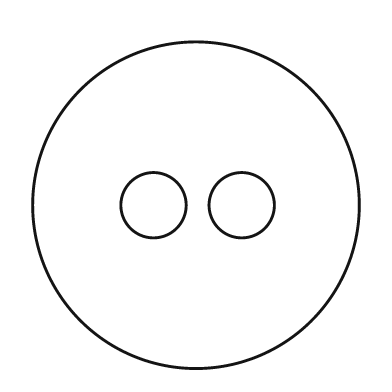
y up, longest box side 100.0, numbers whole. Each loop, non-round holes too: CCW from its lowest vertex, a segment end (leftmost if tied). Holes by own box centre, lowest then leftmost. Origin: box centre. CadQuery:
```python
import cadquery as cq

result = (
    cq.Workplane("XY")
    .moveTo(0.0, 0.0)
    .circle(50.0)
    .moveTo(-13.0, 0.0)
    .circle(10.0)
    .moveTo(14.0, 0.0)
    .circle(10.0)
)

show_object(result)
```